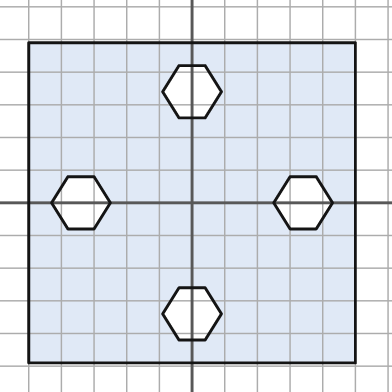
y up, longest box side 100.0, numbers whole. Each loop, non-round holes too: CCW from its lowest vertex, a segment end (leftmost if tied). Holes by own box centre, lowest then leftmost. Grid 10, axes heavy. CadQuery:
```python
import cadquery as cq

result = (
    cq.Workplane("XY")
    .moveTo(-50.0, -49.0)
    .lineTo(50.0, -49.0)
    .lineTo(50.0, 49.0)
    .lineTo(-50.0, 49.0)
    .close()
    .moveTo(-4.0, -42.0)
    .lineTo(4.0, -42.0)
    .lineTo(9.0, -34.0)
    .lineTo(4.0, -26.0)
    .lineTo(-4.0, -26.0)
    .lineTo(-9.0, -34.0)
    .close()
    .moveTo(-38.0, -8.0)
    .lineTo(-30.0, -8.0)
    .lineTo(-25.0, 0.0)
    .lineTo(-30.0, 8.0)
    .lineTo(-38.0, 8.0)
    .lineTo(-43.0, 0.0)
    .close()
    .moveTo(30.0, -8.0)
    .lineTo(38.0, -8.0)
    .lineTo(43.0, 0.0)
    .lineTo(38.0, 8.0)
    .lineTo(30.0, 8.0)
    .lineTo(25.0, 0.0)
    .close()
    .moveTo(-4.0, 26.0)
    .lineTo(4.0, 26.0)
    .lineTo(9.0, 34.0)
    .lineTo(4.0, 42.0)
    .lineTo(-4.0, 42.0)
    .lineTo(-9.0, 34.0)
    .close()
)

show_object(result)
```